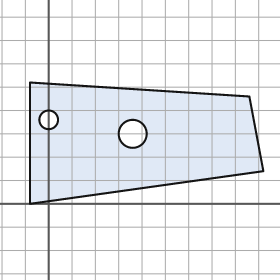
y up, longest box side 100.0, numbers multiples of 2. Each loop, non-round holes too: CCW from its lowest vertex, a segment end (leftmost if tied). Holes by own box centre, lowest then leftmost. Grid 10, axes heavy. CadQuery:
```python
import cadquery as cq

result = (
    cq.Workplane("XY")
    .moveTo(-8.0, 0.0)
    .lineTo(92.0, 14.0)
    .lineTo(86.0, 46.0)
    .lineTo(-8.0, 52.0)
    .close()
    .moveTo(36.0, 30.0)
    .circle(6.0)
    .moveTo(0.0, 36.0)
    .circle(4.0)
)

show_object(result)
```